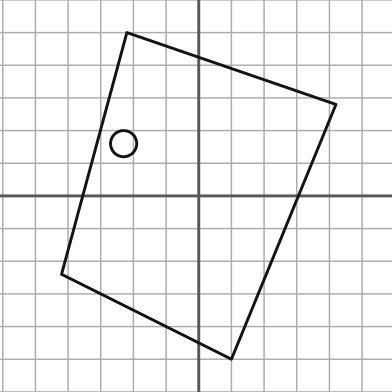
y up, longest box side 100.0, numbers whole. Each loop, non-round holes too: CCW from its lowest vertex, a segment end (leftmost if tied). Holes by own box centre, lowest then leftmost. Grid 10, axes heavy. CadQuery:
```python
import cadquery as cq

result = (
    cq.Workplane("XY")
    .moveTo(10.0, -50.0)
    .lineTo(42.0, 28.0)
    .lineTo(-22.0, 50.0)
    .lineTo(-42.0, -24.0)
    .close()
    .moveTo(-23.0, 16.0)
    .circle(4.0)
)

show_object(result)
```